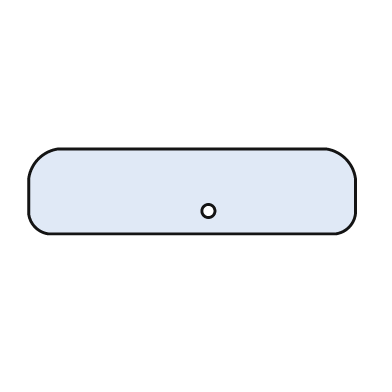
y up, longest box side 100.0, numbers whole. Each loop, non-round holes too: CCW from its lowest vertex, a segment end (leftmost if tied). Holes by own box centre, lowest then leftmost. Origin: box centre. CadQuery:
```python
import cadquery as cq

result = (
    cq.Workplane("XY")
    .moveTo(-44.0, -13.0)
    .lineTo(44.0, -13.0)
    .threePointArc((48.0, -11.0), (50.0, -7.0))
    .lineTo(50.0, 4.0)
    .threePointArc((47.0, 10.0), (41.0, 13.0))
    .lineTo(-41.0, 13.0)
    .threePointArc((-47.0, 10.0), (-50.0, 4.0))
    .lineTo(-50.0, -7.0)
    .threePointArc((-48.0, -11.0), (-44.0, -13.0))
    .close()
    .moveTo(5.0, -6.0)
    .circle(2.0)
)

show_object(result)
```